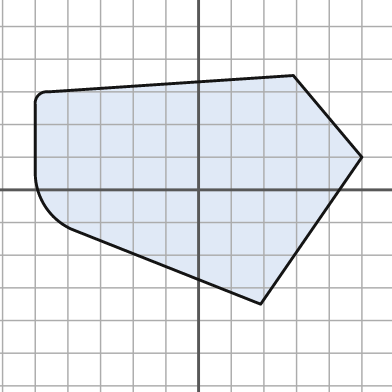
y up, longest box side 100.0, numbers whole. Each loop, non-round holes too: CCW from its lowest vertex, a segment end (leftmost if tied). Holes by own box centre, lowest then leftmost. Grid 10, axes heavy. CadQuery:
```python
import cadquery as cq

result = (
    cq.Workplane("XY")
    .moveTo(19.0, -35.0)
    .lineTo(50.0, 10.0)
    .lineTo(29.0, 35.0)
    .lineTo(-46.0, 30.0)
    .threePointArc((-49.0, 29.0), (-50.0, 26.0))
    .lineTo(-50.0, 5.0)
    .threePointArc((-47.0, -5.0), (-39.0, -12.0))
    .close()
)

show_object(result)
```